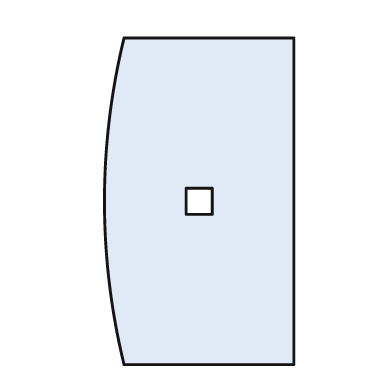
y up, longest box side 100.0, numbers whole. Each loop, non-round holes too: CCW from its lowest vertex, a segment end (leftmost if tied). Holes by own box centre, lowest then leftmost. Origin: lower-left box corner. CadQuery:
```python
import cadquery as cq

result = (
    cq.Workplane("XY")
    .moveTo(6.0, 0.0)
    .lineTo(58.0, 0.0)
    .lineTo(58.0, 100.0)
    .lineTo(6.0, 100.0)
    .threePointArc((0.0, 50.0), (6.0, 0.0))
    .close()
    .moveTo(25.0, 46.0)
    .lineTo(33.0, 46.0)
    .lineTo(33.0, 54.0)
    .lineTo(25.0, 54.0)
    .close()
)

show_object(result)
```